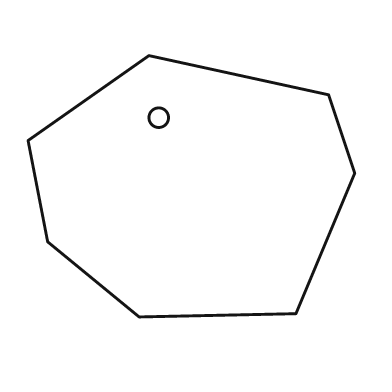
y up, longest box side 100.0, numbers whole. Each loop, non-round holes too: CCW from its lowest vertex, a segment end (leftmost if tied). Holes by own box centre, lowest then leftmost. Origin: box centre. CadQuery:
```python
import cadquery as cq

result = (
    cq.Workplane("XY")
    .moveTo(-16.0, -40.0)
    .lineTo(32.0, -39.0)
    .lineTo(50.0, 4.0)
    .lineTo(42.0, 28.0)
    .lineTo(-13.0, 40.0)
    .lineTo(-50.0, 14.0)
    .lineTo(-44.0, -17.0)
    .close()
    .moveTo(-10.0, 21.0)
    .circle(3.0)
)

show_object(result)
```